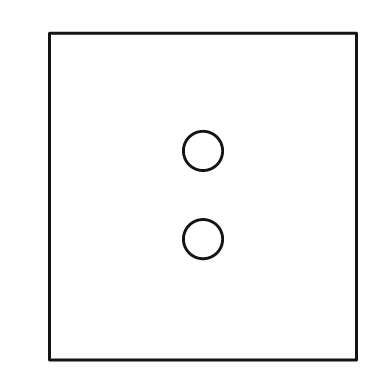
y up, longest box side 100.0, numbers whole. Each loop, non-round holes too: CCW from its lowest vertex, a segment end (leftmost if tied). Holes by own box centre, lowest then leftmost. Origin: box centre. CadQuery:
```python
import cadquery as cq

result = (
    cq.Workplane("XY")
    .moveTo(-47.0, -50.0)
    .lineTo(47.0, -50.0)
    .lineTo(47.0, 50.0)
    .lineTo(-47.0, 50.0)
    .close()
    .moveTo(0.0, -13.0)
    .circle(6.0)
    .moveTo(0.0, 14.0)
    .circle(6.0)
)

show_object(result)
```